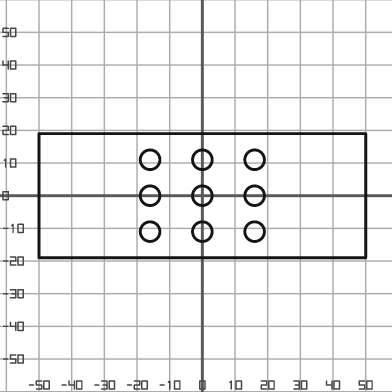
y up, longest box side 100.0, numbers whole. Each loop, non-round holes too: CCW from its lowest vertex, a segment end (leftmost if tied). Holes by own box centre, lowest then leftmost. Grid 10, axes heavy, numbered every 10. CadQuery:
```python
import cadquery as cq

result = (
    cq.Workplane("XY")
    .moveTo(-50.0, -19.0)
    .lineTo(50.0, -19.0)
    .lineTo(50.0, 19.0)
    .lineTo(-50.0, 19.0)
    .close()
    .moveTo(-16.0, -11.0)
    .circle(3.0)
    .moveTo(0.0, -11.0)
    .circle(3.0)
    .moveTo(16.0, -11.0)
    .circle(3.0)
    .moveTo(-16.0, 0.0)
    .circle(3.0)
    .moveTo(0.0, 0.0)
    .circle(3.0)
    .moveTo(16.0, 0.0)
    .circle(3.0)
    .moveTo(-16.0, 11.0)
    .circle(3.0)
    .moveTo(0.0, 11.0)
    .circle(3.0)
    .moveTo(16.0, 11.0)
    .circle(3.0)
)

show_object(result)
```